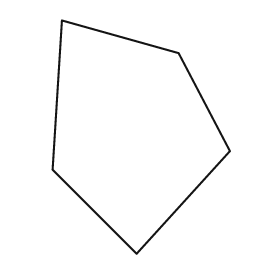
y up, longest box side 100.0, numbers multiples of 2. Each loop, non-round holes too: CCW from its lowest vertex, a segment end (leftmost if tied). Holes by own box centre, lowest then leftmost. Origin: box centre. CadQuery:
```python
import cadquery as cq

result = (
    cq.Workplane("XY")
    .moveTo(-2.0, -50.0)
    .lineTo(38.0, -6.0)
    .lineTo(16.0, 36.0)
    .lineTo(-34.0, 50.0)
    .lineTo(-38.0, -14.0)
    .close()
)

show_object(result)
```